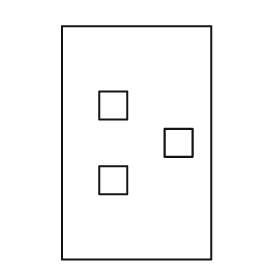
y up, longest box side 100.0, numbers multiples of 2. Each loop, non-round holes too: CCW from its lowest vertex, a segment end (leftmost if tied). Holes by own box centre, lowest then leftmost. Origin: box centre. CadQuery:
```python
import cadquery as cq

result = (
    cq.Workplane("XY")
    .moveTo(-32.0, -50.0)
    .lineTo(32.0, -50.0)
    .lineTo(32.0, 50.0)
    .lineTo(-32.0, 50.0)
    .close()
    .moveTo(-16.0, -22.0)
    .lineTo(-4.0, -22.0)
    .lineTo(-4.0, -10.0)
    .lineTo(-16.0, -10.0)
    .close()
    .moveTo(12.0, -6.0)
    .lineTo(24.0, -6.0)
    .lineTo(24.0, 6.0)
    .lineTo(12.0, 6.0)
    .close()
    .moveTo(-16.0, 10.0)
    .lineTo(-4.0, 10.0)
    .lineTo(-4.0, 22.0)
    .lineTo(-16.0, 22.0)
    .close()
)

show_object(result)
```